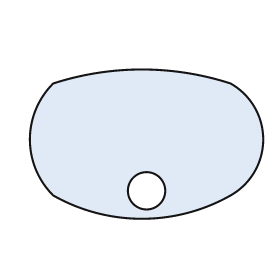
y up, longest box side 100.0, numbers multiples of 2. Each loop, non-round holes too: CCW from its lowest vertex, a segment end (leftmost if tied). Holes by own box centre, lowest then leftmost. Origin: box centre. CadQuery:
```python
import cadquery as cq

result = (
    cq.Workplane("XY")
    .moveTo(-40.0, -22.0)
    .threePointArc((-2.0, -32.0), (36.0, -22.0))
    .threePointArc((50.0, 2.0), (36.0, 26.0))
    .threePointArc((-2.0, 32.0), (-40.0, 26.0))
    .threePointArc((-50.0, 2.0), (-40.0, -22.0))
    .close()
    .moveTo(0.0, -20.0)
    .circle(8.0)
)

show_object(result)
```